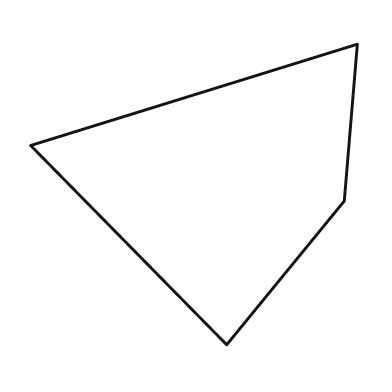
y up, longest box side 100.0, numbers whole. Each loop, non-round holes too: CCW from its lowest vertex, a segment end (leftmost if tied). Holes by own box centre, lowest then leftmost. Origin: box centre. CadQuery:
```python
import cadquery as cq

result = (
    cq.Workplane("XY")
    .moveTo(10.0, -46.0)
    .lineTo(46.0, -2.0)
    .lineTo(50.0, 46.0)
    .lineTo(-50.0, 15.0)
    .close()
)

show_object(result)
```